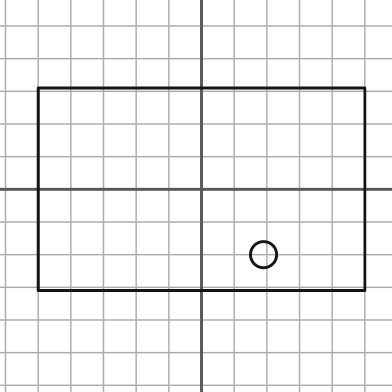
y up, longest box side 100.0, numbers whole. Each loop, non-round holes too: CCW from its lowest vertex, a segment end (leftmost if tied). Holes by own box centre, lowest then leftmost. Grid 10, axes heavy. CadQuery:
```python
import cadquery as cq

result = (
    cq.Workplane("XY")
    .moveTo(-50.0, -31.0)
    .lineTo(50.0, -31.0)
    .lineTo(50.0, 31.0)
    .lineTo(-50.0, 31.0)
    .close()
    .moveTo(19.0, -20.0)
    .circle(4.0)
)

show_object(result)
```